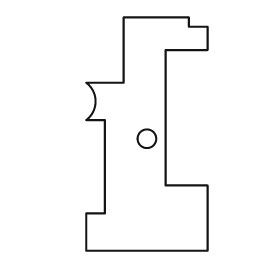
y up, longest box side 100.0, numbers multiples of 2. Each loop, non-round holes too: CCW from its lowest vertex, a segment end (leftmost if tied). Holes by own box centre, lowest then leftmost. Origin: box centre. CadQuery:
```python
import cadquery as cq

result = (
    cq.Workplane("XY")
    .moveTo(-26.0, -50.0)
    .lineTo(26.0, -50.0)
    .lineTo(26.0, -22.0)
    .lineTo(8.0, -22.0)
    .lineTo(8.0, 36.0)
    .lineTo(26.0, 36.0)
    .lineTo(26.0, 46.0)
    .lineTo(18.0, 46.0)
    .lineTo(18.0, 50.0)
    .lineTo(-10.0, 50.0)
    .lineTo(-10.0, 22.0)
    .lineTo(-26.0, 22.0)
    .threePointArc((-22.0, 14.0), (-26.0, 6.0))
    .lineTo(-18.0, 6.0)
    .lineTo(-18.0, -34.0)
    .lineTo(-26.0, -34.0)
    .close()
    .moveTo(0.0, -2.0)
    .circle(4.0)
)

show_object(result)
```